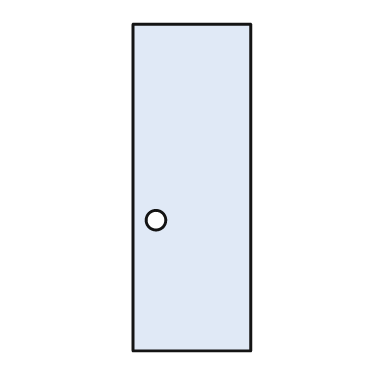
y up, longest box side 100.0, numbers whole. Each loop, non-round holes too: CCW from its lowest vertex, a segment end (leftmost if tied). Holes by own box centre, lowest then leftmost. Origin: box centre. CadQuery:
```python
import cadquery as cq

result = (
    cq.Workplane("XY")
    .moveTo(-18.0, -50.0)
    .lineTo(18.0, -50.0)
    .lineTo(18.0, 50.0)
    .lineTo(-18.0, 50.0)
    .close()
    .moveTo(-11.0, -10.0)
    .circle(3.0)
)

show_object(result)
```